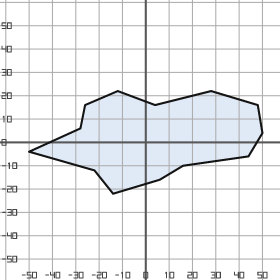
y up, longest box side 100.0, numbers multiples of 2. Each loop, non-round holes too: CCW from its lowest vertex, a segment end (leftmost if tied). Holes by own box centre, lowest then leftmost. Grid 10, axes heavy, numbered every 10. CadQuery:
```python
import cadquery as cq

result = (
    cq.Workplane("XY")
    .moveTo(-14.0, -22.0)
    .lineTo(6.0, -16.0)
    .lineTo(16.0, -10.0)
    .lineTo(44.0, -6.0)
    .lineTo(50.0, 4.0)
    .lineTo(48.0, 16.0)
    .lineTo(28.0, 22.0)
    .lineTo(4.0, 16.0)
    .lineTo(-12.0, 22.0)
    .lineTo(-26.0, 16.0)
    .lineTo(-28.0, 6.0)
    .lineTo(-50.0, -4.0)
    .lineTo(-22.0, -12.0)
    .close()
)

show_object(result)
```